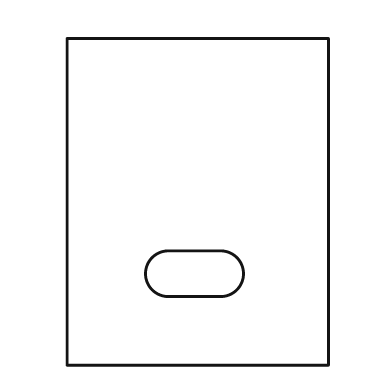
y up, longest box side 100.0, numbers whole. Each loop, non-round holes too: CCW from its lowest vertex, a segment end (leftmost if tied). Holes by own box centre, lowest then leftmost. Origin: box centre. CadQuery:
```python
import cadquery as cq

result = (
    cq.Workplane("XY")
    .moveTo(-40.0, -50.0)
    .lineTo(40.0, -50.0)
    .lineTo(40.0, 50.0)
    .lineTo(-40.0, 50.0)
    .close()
    .moveTo(-9.0, -29.0)
    .lineTo(7.0, -29.0)
    .threePointArc((14.0, -22.0), (7.0, -15.0))
    .lineTo(-9.0, -15.0)
    .threePointArc((-16.0, -22.0), (-9.0, -29.0))
    .close()
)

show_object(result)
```